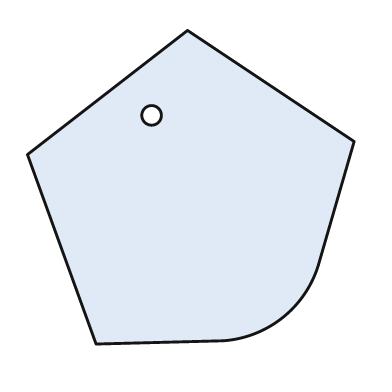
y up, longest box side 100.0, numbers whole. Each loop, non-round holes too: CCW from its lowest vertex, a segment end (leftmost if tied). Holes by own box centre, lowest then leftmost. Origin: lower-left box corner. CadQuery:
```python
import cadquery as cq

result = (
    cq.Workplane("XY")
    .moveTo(21.0, 0.0)
    .lineTo(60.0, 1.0)
    .threePointArc((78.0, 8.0), (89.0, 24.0))
    .lineTo(100.0, 62.0)
    .lineTo(49.0, 96.0)
    .lineTo(0.0, 58.0)
    .close()
    .moveTo(38.0, 70.0)
    .circle(3.0)
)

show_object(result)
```